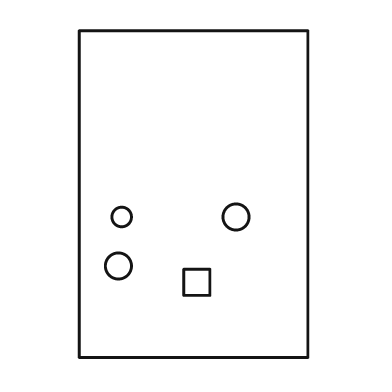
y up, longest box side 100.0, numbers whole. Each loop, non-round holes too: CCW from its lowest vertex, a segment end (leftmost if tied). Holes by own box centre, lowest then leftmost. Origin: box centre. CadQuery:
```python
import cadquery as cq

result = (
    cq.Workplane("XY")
    .moveTo(-35.0, -50.0)
    .lineTo(35.0, -50.0)
    .lineTo(35.0, 50.0)
    .lineTo(-35.0, 50.0)
    .close()
    .moveTo(-3.0, -31.0)
    .lineTo(5.0, -31.0)
    .lineTo(5.0, -23.0)
    .lineTo(-3.0, -23.0)
    .close()
    .moveTo(-23.0, -22.0)
    .circle(4.0)
    .moveTo(-22.0, -7.0)
    .circle(3.0)
    .moveTo(13.0, -7.0)
    .circle(4.0)
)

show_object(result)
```